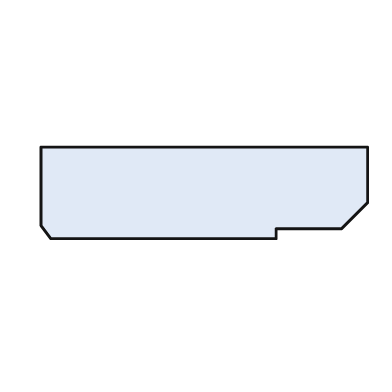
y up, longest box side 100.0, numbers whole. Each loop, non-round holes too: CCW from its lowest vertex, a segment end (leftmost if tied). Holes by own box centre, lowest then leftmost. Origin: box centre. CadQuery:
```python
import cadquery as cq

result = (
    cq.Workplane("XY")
    .moveTo(-47.0, -14.0)
    .lineTo(22.0, -14.0)
    .lineTo(22.0, -11.0)
    .lineTo(42.0, -11.0)
    .lineTo(50.0, -3.0)
    .lineTo(50.0, 14.0)
    .lineTo(-50.0, 14.0)
    .lineTo(-50.0, -10.0)
    .close()
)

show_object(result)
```